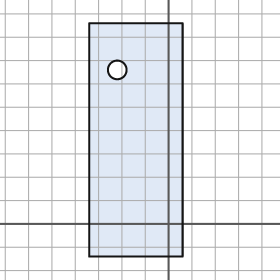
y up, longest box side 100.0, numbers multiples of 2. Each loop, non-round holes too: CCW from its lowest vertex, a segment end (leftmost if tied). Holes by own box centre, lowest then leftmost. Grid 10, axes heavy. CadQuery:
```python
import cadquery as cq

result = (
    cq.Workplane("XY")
    .moveTo(-34.0, -14.0)
    .lineTo(6.0, -14.0)
    .lineTo(6.0, 86.0)
    .lineTo(-34.0, 86.0)
    .close()
    .moveTo(-22.0, 66.0)
    .circle(4.0)
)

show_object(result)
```